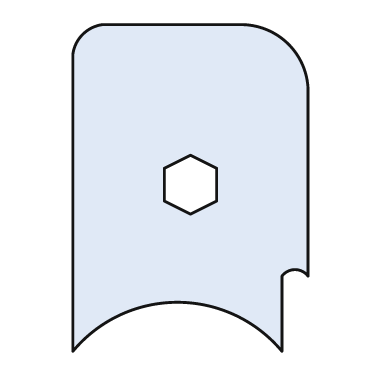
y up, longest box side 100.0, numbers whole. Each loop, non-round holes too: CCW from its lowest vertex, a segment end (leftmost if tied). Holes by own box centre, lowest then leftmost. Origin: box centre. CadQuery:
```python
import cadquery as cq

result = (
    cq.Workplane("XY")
    .moveTo(-36.0, -50.0)
    .threePointArc((-4.0, -35.0), (28.0, -50.0))
    .lineTo(28.0, -27.0)
    .threePointArc((32.0, -25.0), (36.0, -27.0))
    .lineTo(36.0, 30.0)
    .threePointArc((30.0, 44.0), (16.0, 50.0))
    .lineTo(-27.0, 50.0)
    .threePointArc((-33.0, 47.0), (-36.0, 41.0))
    .close()
    .moveTo(0.0, -8.0)
    .lineTo(8.0, -4.0)
    .lineTo(8.0, 6.0)
    .lineTo(0.0, 10.0)
    .lineTo(-8.0, 6.0)
    .lineTo(-8.0, -4.0)
    .close()
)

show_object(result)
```